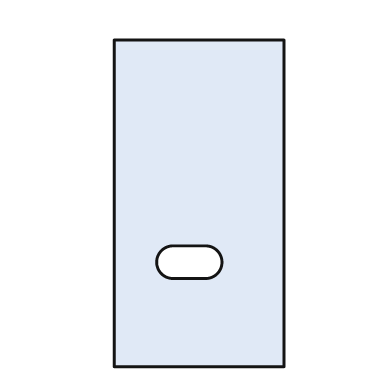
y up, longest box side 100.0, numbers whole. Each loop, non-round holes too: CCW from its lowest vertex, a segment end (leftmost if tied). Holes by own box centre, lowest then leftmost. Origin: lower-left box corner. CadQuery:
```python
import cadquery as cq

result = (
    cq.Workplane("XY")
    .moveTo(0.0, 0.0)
    .lineTo(52.0, 0.0)
    .lineTo(52.0, 100.0)
    .lineTo(0.0, 100.0)
    .close()
    .moveTo(18.0, 27.0)
    .lineTo(28.0, 27.0)
    .threePointArc((33.0, 32.0), (28.0, 37.0))
    .lineTo(18.0, 37.0)
    .threePointArc((13.0, 32.0), (18.0, 27.0))
    .close()
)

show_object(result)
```